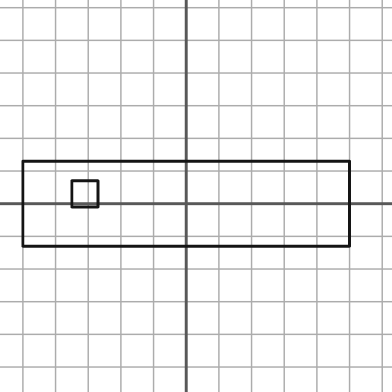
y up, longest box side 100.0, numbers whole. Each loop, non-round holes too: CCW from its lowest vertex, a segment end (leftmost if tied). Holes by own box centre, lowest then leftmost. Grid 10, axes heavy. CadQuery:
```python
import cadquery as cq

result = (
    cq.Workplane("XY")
    .moveTo(-50.0, -13.0)
    .lineTo(50.0, -13.0)
    .lineTo(50.0, 13.0)
    .lineTo(-50.0, 13.0)
    .close()
    .moveTo(-35.0, -1.0)
    .lineTo(-27.0, -1.0)
    .lineTo(-27.0, 7.0)
    .lineTo(-35.0, 7.0)
    .close()
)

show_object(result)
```